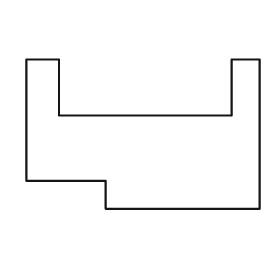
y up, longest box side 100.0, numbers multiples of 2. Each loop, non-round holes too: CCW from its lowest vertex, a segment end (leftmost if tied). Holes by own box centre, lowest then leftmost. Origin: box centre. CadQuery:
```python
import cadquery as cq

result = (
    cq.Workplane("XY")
    .moveTo(-16.0, -32.0)
    .lineTo(50.0, -32.0)
    .lineTo(50.0, 32.0)
    .lineTo(38.0, 32.0)
    .lineTo(38.0, 8.0)
    .lineTo(-36.0, 8.0)
    .lineTo(-36.0, 32.0)
    .lineTo(-50.0, 32.0)
    .lineTo(-50.0, -20.0)
    .lineTo(-16.0, -20.0)
    .close()
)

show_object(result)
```